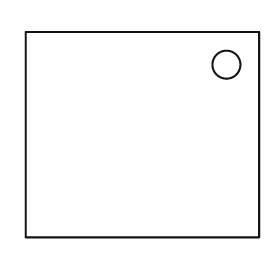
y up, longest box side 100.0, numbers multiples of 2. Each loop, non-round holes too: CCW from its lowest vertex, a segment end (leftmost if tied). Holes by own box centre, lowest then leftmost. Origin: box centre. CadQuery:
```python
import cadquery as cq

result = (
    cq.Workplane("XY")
    .moveTo(-50.0, -44.0)
    .lineTo(50.0, -44.0)
    .lineTo(50.0, 44.0)
    .lineTo(-50.0, 44.0)
    .close()
    .moveTo(36.0, 30.0)
    .circle(6.0)
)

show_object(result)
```